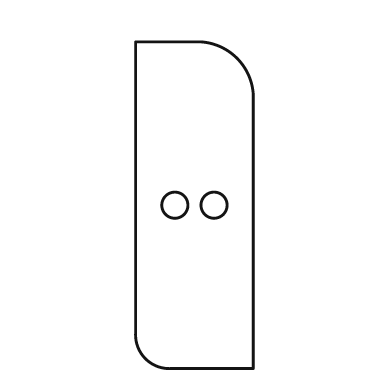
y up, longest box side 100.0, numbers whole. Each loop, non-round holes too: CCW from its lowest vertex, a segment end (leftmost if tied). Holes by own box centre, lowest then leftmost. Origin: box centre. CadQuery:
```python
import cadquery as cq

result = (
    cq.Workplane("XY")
    .moveTo(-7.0, -50.0)
    .lineTo(18.0, -50.0)
    .lineTo(18.0, 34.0)
    .threePointArc((13.0, 45.0), (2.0, 50.0))
    .lineTo(-18.0, 50.0)
    .lineTo(-18.0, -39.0)
    .threePointArc((-15.0, -47.0), (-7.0, -50.0))
    .close()
    .moveTo(-6.0, 0.0)
    .circle(4.0)
    .moveTo(6.0, 0.0)
    .circle(4.0)
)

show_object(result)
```